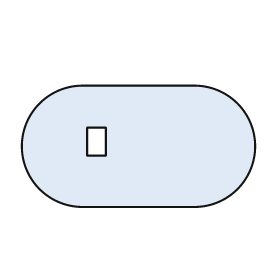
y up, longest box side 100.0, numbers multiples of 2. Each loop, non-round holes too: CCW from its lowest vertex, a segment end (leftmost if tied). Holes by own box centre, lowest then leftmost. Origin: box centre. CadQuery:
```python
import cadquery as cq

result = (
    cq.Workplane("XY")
    .moveTo(-24.0, -26.0)
    .lineTo(24.0, -26.0)
    .threePointArc((50.0, 0.0), (24.0, 26.0))
    .lineTo(-24.0, 26.0)
    .threePointArc((-50.0, 0.0), (-24.0, -26.0))
    .close()
    .moveTo(-22.0, -4.0)
    .lineTo(-14.0, -4.0)
    .lineTo(-14.0, 8.0)
    .lineTo(-22.0, 8.0)
    .close()
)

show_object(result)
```